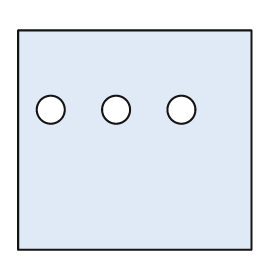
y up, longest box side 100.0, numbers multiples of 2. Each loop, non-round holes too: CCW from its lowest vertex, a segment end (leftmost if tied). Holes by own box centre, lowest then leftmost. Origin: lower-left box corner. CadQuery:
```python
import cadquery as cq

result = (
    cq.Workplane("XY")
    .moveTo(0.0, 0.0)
    .lineTo(100.0, 0.0)
    .lineTo(100.0, 94.0)
    .lineTo(0.0, 94.0)
    .close()
    .moveTo(14.0, 60.0)
    .circle(6.0)
    .moveTo(42.0, 60.0)
    .circle(6.0)
    .moveTo(70.0, 60.0)
    .circle(6.0)
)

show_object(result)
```